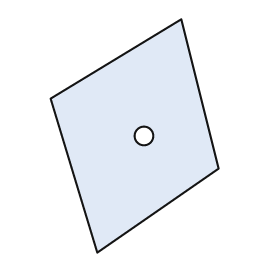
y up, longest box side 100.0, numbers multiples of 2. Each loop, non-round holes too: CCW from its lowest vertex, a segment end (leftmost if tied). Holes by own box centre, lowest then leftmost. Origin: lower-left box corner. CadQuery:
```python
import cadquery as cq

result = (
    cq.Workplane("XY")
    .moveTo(20.0, 0.0)
    .lineTo(72.0, 36.0)
    .lineTo(56.0, 100.0)
    .lineTo(0.0, 66.0)
    .close()
    .moveTo(40.0, 50.0)
    .circle(4.0)
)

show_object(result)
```